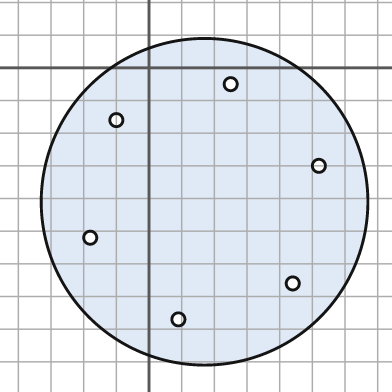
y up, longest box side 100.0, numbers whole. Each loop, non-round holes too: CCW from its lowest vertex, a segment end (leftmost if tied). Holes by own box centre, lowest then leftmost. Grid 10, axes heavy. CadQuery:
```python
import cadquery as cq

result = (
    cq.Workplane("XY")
    .moveTo(17.0, -41.0)
    .circle(50.0)
    .moveTo(9.0, -77.0)
    .circle(2.0)
    .moveTo(44.0, -66.0)
    .circle(2.0)
    .moveTo(-18.0, -52.0)
    .circle(2.0)
    .moveTo(52.0, -30.0)
    .circle(2.0)
    .moveTo(-10.0, -16.0)
    .circle(2.0)
    .moveTo(25.0, -5.0)
    .circle(2.0)
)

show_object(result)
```